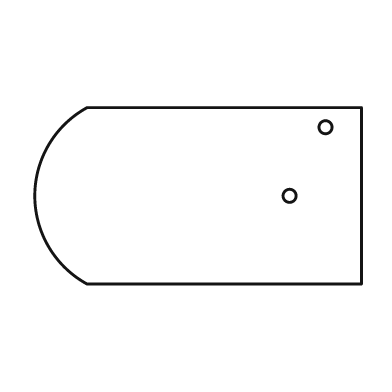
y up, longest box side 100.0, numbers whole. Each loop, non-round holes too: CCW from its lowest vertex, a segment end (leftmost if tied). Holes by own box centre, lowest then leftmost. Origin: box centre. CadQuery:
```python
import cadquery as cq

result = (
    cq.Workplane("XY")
    .moveTo(-34.0, -27.0)
    .lineTo(50.0, -27.0)
    .lineTo(50.0, 27.0)
    .lineTo(-34.0, 27.0)
    .threePointArc((-50.0, 0.0), (-34.0, -27.0))
    .close()
    .moveTo(28.0, 0.0)
    .circle(2.0)
    .moveTo(39.0, 21.0)
    .circle(2.0)
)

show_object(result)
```